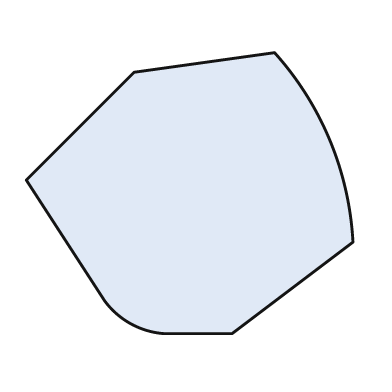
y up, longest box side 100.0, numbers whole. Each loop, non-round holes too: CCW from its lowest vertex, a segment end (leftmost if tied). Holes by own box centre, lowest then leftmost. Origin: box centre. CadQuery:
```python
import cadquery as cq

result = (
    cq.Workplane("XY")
    .moveTo(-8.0, -43.0)
    .lineTo(13.0, -43.0)
    .lineTo(50.0, -15.0)
    .threePointArc((43.0, 16.0), (26.0, 43.0))
    .lineTo(-17.0, 37.0)
    .lineTo(-50.0, 4.0)
    .lineTo(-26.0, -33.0)
    .threePointArc((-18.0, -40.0), (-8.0, -43.0))
    .close()
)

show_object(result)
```